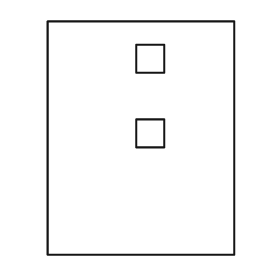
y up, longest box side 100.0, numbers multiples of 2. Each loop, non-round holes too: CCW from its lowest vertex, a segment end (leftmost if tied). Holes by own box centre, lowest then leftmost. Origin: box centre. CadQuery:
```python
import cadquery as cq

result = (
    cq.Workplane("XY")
    .moveTo(-40.0, -50.0)
    .lineTo(40.0, -50.0)
    .lineTo(40.0, 50.0)
    .lineTo(-40.0, 50.0)
    .close()
    .moveTo(-2.0, -4.0)
    .lineTo(10.0, -4.0)
    .lineTo(10.0, 8.0)
    .lineTo(-2.0, 8.0)
    .close()
    .moveTo(-2.0, 28.0)
    .lineTo(10.0, 28.0)
    .lineTo(10.0, 40.0)
    .lineTo(-2.0, 40.0)
    .close()
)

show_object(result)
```